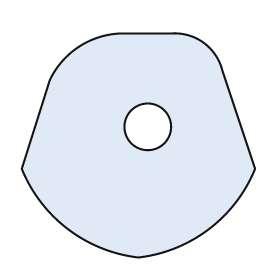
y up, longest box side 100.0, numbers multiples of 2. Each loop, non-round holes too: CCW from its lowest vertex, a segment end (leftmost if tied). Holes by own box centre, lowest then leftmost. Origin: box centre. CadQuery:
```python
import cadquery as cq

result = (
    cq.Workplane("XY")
    .moveTo(0.0, -48.0)
    .threePointArc((30.0, -36.0), (50.0, -10.0))
    .lineTo(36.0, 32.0)
    .threePointArc((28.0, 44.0), (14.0, 48.0))
    .lineTo(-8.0, 48.0)
    .threePointArc((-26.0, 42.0), (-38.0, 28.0))
    .lineTo(-50.0, -10.0)
    .threePointArc((-30.0, -36.0), (0.0, -48.0))
    .close()
    .moveTo(4.0, 8.0)
    .circle(10.0)
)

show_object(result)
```